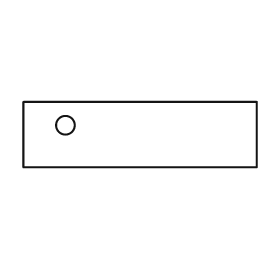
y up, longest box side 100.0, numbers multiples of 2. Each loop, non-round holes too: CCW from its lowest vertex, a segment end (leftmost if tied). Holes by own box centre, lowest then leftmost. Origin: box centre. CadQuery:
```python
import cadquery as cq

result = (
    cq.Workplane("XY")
    .moveTo(-50.0, -14.0)
    .lineTo(50.0, -14.0)
    .lineTo(50.0, 14.0)
    .lineTo(-50.0, 14.0)
    .close()
    .moveTo(-32.0, 4.0)
    .circle(4.0)
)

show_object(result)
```